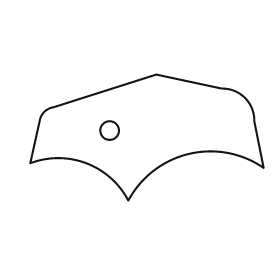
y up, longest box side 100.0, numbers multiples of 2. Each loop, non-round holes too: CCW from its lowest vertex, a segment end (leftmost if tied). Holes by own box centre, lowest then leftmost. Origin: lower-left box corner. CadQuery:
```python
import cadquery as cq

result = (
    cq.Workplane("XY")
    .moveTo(42.0, 0.0)
    .threePointArc((68.0, 20.0), (100.0, 14.0))
    .lineTo(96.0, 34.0)
    .threePointArc((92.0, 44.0), (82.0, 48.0))
    .lineTo(54.0, 54.0)
    .lineTo(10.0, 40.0)
    .threePointArc((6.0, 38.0), (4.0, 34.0))
    .lineTo(0.0, 16.0)
    .threePointArc((24.0, 16.0), (42.0, 0.0))
    .close()
    .moveTo(34.0, 30.0)
    .circle(4.0)
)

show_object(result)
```